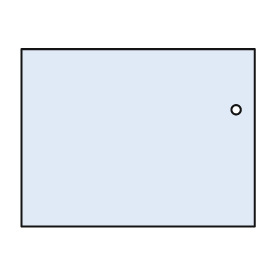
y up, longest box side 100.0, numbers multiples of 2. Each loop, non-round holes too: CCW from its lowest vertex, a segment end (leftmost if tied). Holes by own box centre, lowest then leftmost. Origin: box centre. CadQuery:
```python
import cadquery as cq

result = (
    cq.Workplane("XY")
    .moveTo(-50.0, -38.0)
    .lineTo(50.0, -38.0)
    .lineTo(50.0, 38.0)
    .lineTo(-50.0, 38.0)
    .close()
    .moveTo(42.0, 12.0)
    .circle(2.0)
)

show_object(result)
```